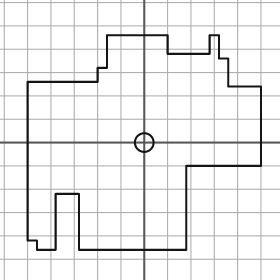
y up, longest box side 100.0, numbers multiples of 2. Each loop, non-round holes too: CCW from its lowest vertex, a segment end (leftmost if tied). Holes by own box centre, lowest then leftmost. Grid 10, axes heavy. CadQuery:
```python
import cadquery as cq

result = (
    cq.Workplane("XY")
    .moveTo(-46.0, -46.0)
    .lineTo(-38.0, -46.0)
    .lineTo(-38.0, -22.0)
    .lineTo(-28.0, -22.0)
    .lineTo(-28.0, -46.0)
    .lineTo(18.0, -46.0)
    .lineTo(18.0, -10.0)
    .lineTo(50.0, -10.0)
    .lineTo(50.0, 24.0)
    .lineTo(36.0, 24.0)
    .lineTo(36.0, 36.0)
    .lineTo(32.0, 36.0)
    .lineTo(32.0, 46.0)
    .lineTo(28.0, 46.0)
    .lineTo(28.0, 38.0)
    .lineTo(10.0, 38.0)
    .lineTo(10.0, 46.0)
    .lineTo(-16.0, 46.0)
    .lineTo(-16.0, 32.0)
    .lineTo(-20.0, 32.0)
    .lineTo(-20.0, 26.0)
    .lineTo(-50.0, 26.0)
    .lineTo(-50.0, -42.0)
    .lineTo(-46.0, -42.0)
    .close()
    .moveTo(0.0, 0.0)
    .circle(4.0)
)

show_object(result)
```